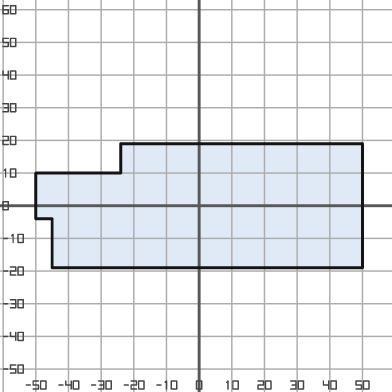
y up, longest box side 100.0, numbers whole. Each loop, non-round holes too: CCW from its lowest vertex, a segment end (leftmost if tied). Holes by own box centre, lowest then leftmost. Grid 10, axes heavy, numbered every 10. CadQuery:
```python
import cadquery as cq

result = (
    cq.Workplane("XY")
    .moveTo(-45.0, -19.0)
    .lineTo(50.0, -19.0)
    .lineTo(50.0, 19.0)
    .lineTo(-24.0, 19.0)
    .lineTo(-24.0, 10.0)
    .lineTo(-50.0, 10.0)
    .lineTo(-50.0, -4.0)
    .lineTo(-45.0, -4.0)
    .close()
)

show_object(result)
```